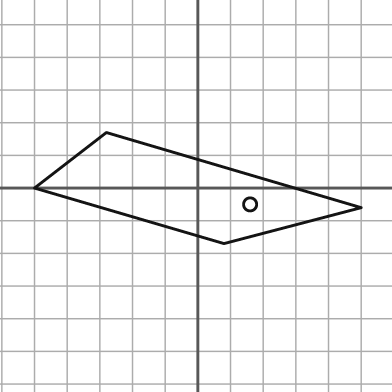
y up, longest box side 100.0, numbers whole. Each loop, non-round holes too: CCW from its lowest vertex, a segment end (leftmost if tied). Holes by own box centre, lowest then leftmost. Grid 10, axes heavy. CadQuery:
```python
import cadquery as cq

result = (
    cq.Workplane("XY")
    .moveTo(8.0, -17.0)
    .lineTo(50.0, -6.0)
    .lineTo(-28.0, 17.0)
    .lineTo(-50.0, 0.0)
    .close()
    .moveTo(16.0, -5.0)
    .circle(2.0)
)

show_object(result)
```